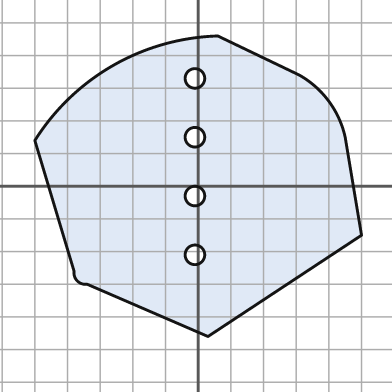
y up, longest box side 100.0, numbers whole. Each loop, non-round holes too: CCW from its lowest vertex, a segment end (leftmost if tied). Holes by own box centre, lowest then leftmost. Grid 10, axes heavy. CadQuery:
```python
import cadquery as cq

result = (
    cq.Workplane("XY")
    .moveTo(3.0, -46.0)
    .lineTo(50.0, -15.0)
    .lineTo(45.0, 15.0)
    .threePointArc((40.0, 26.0), (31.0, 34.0))
    .lineTo(6.0, 46.0)
    .threePointArc((-26.0, 37.0), (-50.0, 14.0))
    .lineTo(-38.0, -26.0)
    .threePointArc((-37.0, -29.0), (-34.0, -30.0))
    .close()
    .moveTo(-1.0, -21.0)
    .circle(3.0)
    .moveTo(-1.0, -3.0)
    .circle(3.0)
    .moveTo(-1.0, 15.0)
    .circle(3.0)
    .moveTo(-1.0, 33.0)
    .circle(3.0)
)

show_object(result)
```